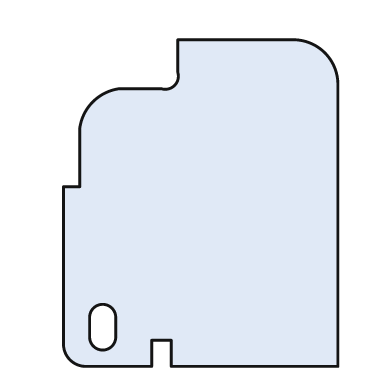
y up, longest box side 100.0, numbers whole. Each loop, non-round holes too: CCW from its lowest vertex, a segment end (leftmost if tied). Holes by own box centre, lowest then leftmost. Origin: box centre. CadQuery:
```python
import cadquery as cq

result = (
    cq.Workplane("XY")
    .moveTo(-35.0, -50.0)
    .lineTo(-15.0, -50.0)
    .lineTo(-15.0, -42.0)
    .lineTo(-9.0, -42.0)
    .lineTo(-9.0, -50.0)
    .lineTo(42.0, -50.0)
    .lineTo(42.0, 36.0)
    .threePointArc((38.0, 46.0), (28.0, 50.0))
    .lineTo(-7.0, 50.0)
    .lineTo(-7.0, 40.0)
    .threePointArc((-8.0, 36.0), (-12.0, 35.0))
    .lineTo(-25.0, 35.0)
    .threePointArc((-33.0, 31.0), (-37.0, 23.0))
    .lineTo(-37.0, 5.0)
    .lineTo(-42.0, 5.0)
    .lineTo(-42.0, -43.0)
    .threePointArc((-40.0, -48.0), (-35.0, -50.0))
    .close()
    .moveTo(-34.0, -41.0)
    .threePointArc((-30.0, -45.0), (-26.0, -41.0))
    .lineTo(-26.0, -35.0)
    .threePointArc((-30.0, -31.0), (-34.0, -35.0))
    .close()
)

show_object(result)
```